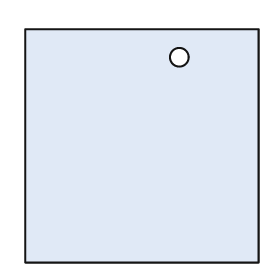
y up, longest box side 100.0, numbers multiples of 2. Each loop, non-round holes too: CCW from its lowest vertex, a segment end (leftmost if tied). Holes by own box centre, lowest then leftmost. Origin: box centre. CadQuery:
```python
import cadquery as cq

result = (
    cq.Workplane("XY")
    .moveTo(-50.0, -50.0)
    .lineTo(50.0, -50.0)
    .lineTo(50.0, 50.0)
    .lineTo(-50.0, 50.0)
    .close()
    .moveTo(16.0, 38.0)
    .circle(4.0)
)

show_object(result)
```